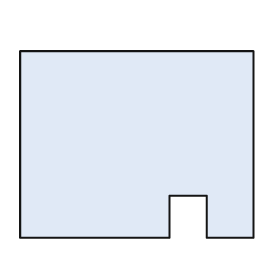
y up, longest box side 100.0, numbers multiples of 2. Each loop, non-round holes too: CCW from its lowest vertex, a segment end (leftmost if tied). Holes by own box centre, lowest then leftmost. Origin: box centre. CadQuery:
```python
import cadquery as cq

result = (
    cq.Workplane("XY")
    .moveTo(-50.0, -40.0)
    .lineTo(14.0, -40.0)
    .lineTo(14.0, -22.0)
    .lineTo(30.0, -22.0)
    .lineTo(30.0, -40.0)
    .lineTo(50.0, -40.0)
    .lineTo(50.0, 40.0)
    .lineTo(-50.0, 40.0)
    .close()
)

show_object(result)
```